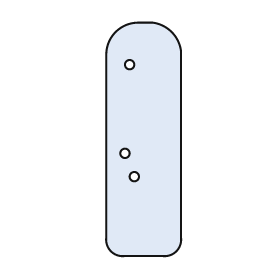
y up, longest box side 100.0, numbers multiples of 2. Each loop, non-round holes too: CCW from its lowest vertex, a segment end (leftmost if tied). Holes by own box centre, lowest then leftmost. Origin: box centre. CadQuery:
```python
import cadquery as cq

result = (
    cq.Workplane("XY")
    .moveTo(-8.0, -50.0)
    .lineTo(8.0, -50.0)
    .threePointArc((14.0, -48.0), (16.0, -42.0))
    .lineTo(16.0, 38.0)
    .threePointArc((12.0, 46.0), (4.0, 50.0))
    .lineTo(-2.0, 50.0)
    .threePointArc((-12.0, 46.0), (-16.0, 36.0))
    .lineTo(-16.0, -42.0)
    .threePointArc((-14.0, -48.0), (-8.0, -50.0))
    .close()
    .moveTo(-4.0, -16.0)
    .circle(2.0)
    .moveTo(-8.0, -6.0)
    .circle(2.0)
    .moveTo(-6.0, 32.0)
    .circle(2.0)
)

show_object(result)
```